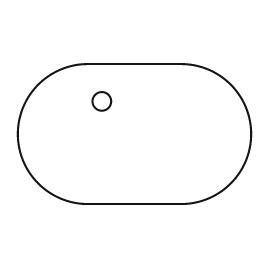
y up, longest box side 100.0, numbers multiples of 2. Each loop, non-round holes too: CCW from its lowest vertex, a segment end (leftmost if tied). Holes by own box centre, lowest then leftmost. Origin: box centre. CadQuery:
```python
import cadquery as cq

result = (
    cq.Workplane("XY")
    .moveTo(-20.0, -30.0)
    .lineTo(20.0, -30.0)
    .threePointArc((50.0, 0.0), (20.0, 30.0))
    .lineTo(-20.0, 30.0)
    .threePointArc((-50.0, 0.0), (-20.0, -30.0))
    .close()
    .moveTo(-14.0, 14.0)
    .circle(4.0)
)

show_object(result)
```